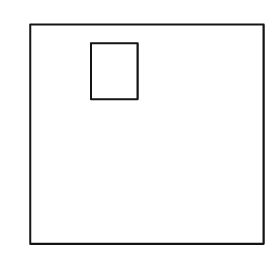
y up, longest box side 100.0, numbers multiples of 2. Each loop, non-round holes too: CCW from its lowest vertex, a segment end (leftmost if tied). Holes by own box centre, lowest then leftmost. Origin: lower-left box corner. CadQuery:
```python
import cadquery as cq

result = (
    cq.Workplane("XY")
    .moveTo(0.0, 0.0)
    .lineTo(100.0, 0.0)
    .lineTo(100.0, 94.0)
    .lineTo(0.0, 94.0)
    .close()
    .moveTo(26.0, 62.0)
    .lineTo(46.0, 62.0)
    .lineTo(46.0, 86.0)
    .lineTo(26.0, 86.0)
    .close()
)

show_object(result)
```